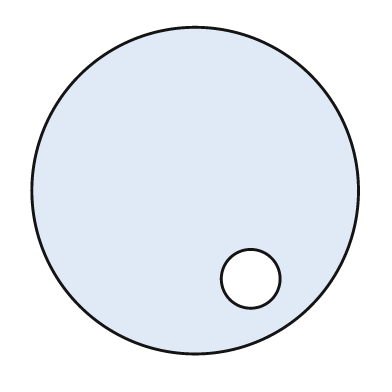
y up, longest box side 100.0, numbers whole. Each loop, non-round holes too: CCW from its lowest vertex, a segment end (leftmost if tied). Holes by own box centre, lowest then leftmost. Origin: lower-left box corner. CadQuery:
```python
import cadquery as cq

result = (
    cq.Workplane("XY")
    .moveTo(50.0, 50.0)
    .circle(50.0)
    .moveTo(67.0, 23.0)
    .circle(9.0)
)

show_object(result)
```